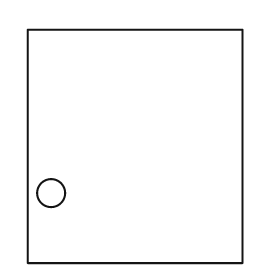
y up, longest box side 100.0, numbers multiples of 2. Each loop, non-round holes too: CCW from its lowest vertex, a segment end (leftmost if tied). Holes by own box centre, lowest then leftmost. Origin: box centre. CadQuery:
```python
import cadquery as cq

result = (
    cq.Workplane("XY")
    .moveTo(-46.0, -50.0)
    .lineTo(46.0, -50.0)
    .lineTo(46.0, 50.0)
    .lineTo(-46.0, 50.0)
    .close()
    .moveTo(-36.0, -20.0)
    .circle(6.0)
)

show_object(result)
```